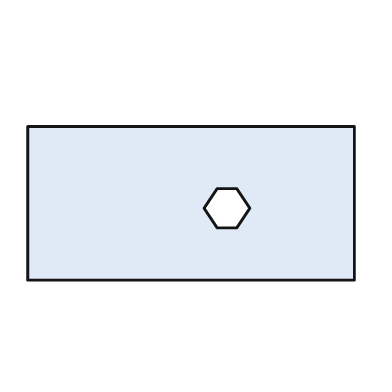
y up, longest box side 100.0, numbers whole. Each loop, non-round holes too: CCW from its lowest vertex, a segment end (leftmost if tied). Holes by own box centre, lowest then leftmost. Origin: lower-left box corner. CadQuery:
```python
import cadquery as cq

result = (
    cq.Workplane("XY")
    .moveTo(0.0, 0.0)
    .lineTo(100.0, 0.0)
    .lineTo(100.0, 47.0)
    .lineTo(0.0, 47.0)
    .close()
    .moveTo(58.0, 16.0)
    .lineTo(64.0, 16.0)
    .lineTo(68.0, 22.0)
    .lineTo(64.0, 28.0)
    .lineTo(58.0, 28.0)
    .lineTo(54.0, 22.0)
    .close()
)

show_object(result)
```